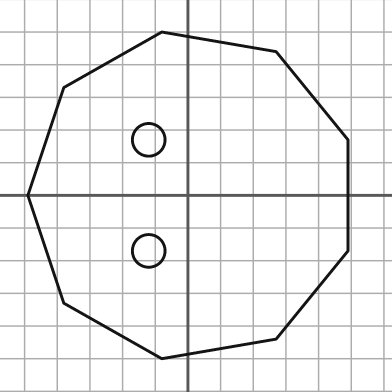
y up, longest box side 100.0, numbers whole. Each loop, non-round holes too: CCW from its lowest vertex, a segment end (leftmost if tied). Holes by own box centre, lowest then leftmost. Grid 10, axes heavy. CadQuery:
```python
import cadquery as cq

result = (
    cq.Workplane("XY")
    .moveTo(-8.0, -50.0)
    .lineTo(27.0, -44.0)
    .lineTo(49.0, -17.0)
    .lineTo(49.0, 17.0)
    .lineTo(27.0, 44.0)
    .lineTo(-8.0, 50.0)
    .lineTo(-38.0, 33.0)
    .lineTo(-49.0, 0.0)
    .lineTo(-38.0, -33.0)
    .close()
    .moveTo(-12.0, -17.0)
    .circle(5.0)
    .moveTo(-12.0, 17.0)
    .circle(5.0)
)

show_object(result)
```